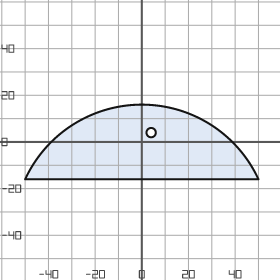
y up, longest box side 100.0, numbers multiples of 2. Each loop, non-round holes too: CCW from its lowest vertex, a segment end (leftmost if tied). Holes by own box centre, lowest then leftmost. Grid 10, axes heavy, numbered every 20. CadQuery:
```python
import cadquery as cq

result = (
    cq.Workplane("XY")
    .moveTo(-50.0, -16.0)
    .lineTo(50.0, -16.0)
    .threePointArc((0.0, 16.0), (-50.0, -16.0))
    .close()
    .moveTo(4.0, 4.0)
    .circle(2.0)
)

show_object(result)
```